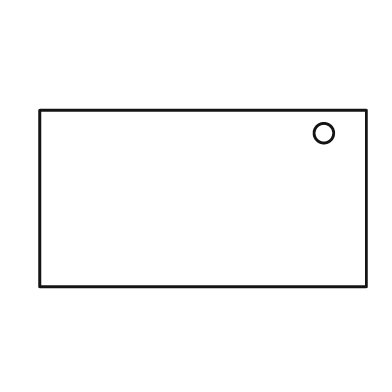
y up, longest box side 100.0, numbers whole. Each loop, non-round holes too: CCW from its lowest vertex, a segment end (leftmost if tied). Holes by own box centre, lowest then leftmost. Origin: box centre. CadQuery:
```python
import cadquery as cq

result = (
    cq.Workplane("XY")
    .moveTo(-50.0, -27.0)
    .lineTo(50.0, -27.0)
    .lineTo(50.0, 27.0)
    .lineTo(-50.0, 27.0)
    .close()
    .moveTo(37.0, 20.0)
    .circle(3.0)
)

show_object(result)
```